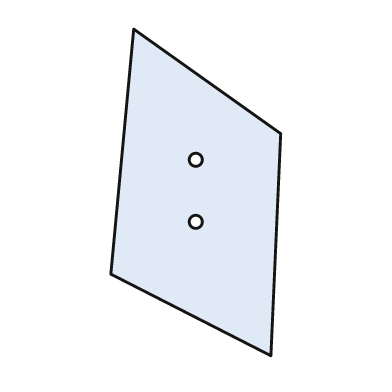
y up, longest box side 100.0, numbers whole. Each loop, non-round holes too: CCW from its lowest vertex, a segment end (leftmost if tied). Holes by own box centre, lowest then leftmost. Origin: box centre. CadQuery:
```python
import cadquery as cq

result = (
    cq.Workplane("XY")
    .moveTo(23.0, -50.0)
    .lineTo(26.0, 18.0)
    .lineTo(-19.0, 50.0)
    .lineTo(-26.0, -25.0)
    .close()
    .moveTo(0.0, -9.0)
    .circle(2.0)
    .moveTo(0.0, 10.0)
    .circle(2.0)
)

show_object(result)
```